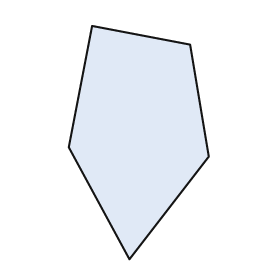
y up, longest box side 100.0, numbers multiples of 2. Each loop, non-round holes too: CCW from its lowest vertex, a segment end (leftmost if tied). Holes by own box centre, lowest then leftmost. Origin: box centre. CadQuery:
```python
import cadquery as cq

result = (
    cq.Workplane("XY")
    .moveTo(-4.0, -50.0)
    .lineTo(30.0, -6.0)
    .lineTo(22.0, 42.0)
    .lineTo(-20.0, 50.0)
    .lineTo(-30.0, -2.0)
    .close()
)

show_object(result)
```